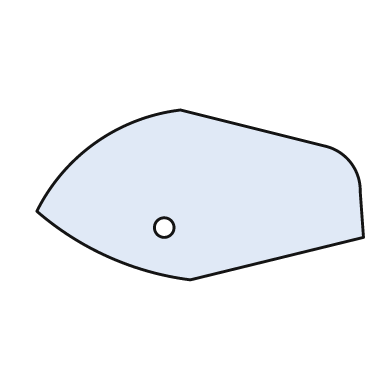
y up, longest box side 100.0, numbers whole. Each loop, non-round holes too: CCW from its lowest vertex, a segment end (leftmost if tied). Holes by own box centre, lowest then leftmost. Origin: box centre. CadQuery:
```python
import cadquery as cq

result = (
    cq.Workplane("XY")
    .moveTo(-3.0, -26.0)
    .lineTo(50.0, -13.0)
    .lineTo(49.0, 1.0)
    .threePointArc((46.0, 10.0), (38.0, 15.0))
    .lineTo(-6.0, 26.0)
    .threePointArc((-32.0, 16.0), (-50.0, -5.0))
    .threePointArc((-28.0, -19.0), (-3.0, -26.0))
    .close()
    .moveTo(-11.0, -10.0)
    .circle(3.0)
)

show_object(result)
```